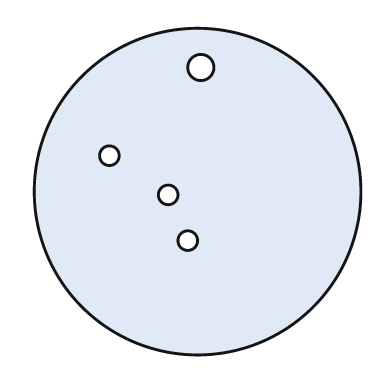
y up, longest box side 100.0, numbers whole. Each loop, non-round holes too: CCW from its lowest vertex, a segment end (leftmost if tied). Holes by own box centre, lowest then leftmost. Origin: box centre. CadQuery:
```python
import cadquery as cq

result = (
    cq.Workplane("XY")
    .moveTo(0.0, 0.0)
    .circle(50.0)
    .moveTo(-3.0, -15.0)
    .circle(3.0)
    .moveTo(-9.0, -1.0)
    .circle(3.0)
    .moveTo(-27.0, 11.0)
    .circle(3.0)
    .moveTo(1.0, 38.0)
    .circle(4.0)
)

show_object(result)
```